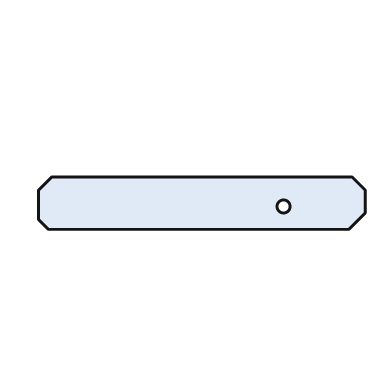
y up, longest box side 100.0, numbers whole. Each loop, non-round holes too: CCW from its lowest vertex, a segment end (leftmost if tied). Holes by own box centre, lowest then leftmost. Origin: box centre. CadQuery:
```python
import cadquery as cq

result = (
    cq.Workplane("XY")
    .moveTo(-47.0, -8.0)
    .lineTo(45.0, -8.0)
    .lineTo(50.0, -3.0)
    .lineTo(50.0, 4.0)
    .lineTo(46.0, 8.0)
    .lineTo(-46.0, 8.0)
    .lineTo(-50.0, 4.0)
    .lineTo(-50.0, -5.0)
    .close()
    .moveTo(25.0, -1.0)
    .circle(2.0)
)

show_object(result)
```